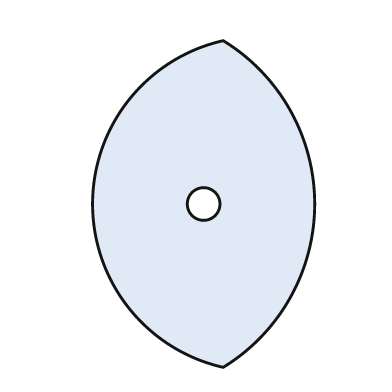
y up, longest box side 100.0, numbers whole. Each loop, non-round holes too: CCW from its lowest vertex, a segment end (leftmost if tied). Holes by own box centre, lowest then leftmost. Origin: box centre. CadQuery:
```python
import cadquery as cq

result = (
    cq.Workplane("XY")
    .moveTo(6.0, -50.0)
    .threePointArc((34.0, 0.0), (6.0, 50.0))
    .threePointArc((-34.0, 0.0), (6.0, -50.0))
    .close()
    .moveTo(0.0, 0.0)
    .circle(5.0)
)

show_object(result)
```